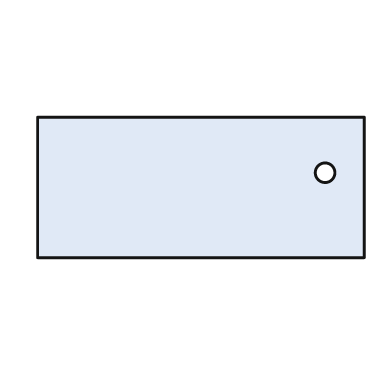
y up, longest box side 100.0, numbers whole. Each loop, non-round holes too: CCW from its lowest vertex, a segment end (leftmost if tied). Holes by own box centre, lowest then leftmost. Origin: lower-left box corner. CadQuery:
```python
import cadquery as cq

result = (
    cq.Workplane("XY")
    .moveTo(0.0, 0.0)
    .lineTo(100.0, 0.0)
    .lineTo(100.0, 43.0)
    .lineTo(0.0, 43.0)
    .close()
    .moveTo(88.0, 26.0)
    .circle(3.0)
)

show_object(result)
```